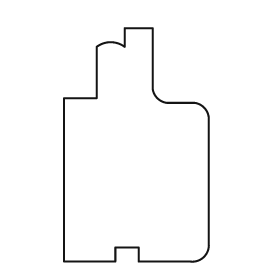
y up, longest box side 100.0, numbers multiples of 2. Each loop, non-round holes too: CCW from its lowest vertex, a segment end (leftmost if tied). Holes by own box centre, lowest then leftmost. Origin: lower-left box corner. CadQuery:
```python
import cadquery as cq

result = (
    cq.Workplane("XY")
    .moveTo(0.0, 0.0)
    .lineTo(22.0, 0.0)
    .lineTo(22.0, 6.0)
    .lineTo(32.0, 6.0)
    .lineTo(32.0, 0.0)
    .lineTo(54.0, 0.0)
    .threePointArc((60.0, 2.0), (62.0, 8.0))
    .lineTo(62.0, 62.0)
    .threePointArc((60.0, 66.0), (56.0, 68.0))
    .lineTo(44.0, 68.0)
    .threePointArc((40.0, 70.0), (38.0, 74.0))
    .lineTo(38.0, 100.0)
    .lineTo(26.0, 100.0)
    .lineTo(26.0, 92.0)
    .threePointArc((20.0, 94.0), (14.0, 92.0))
    .lineTo(14.0, 70.0)
    .lineTo(0.0, 70.0)
    .close()
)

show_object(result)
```